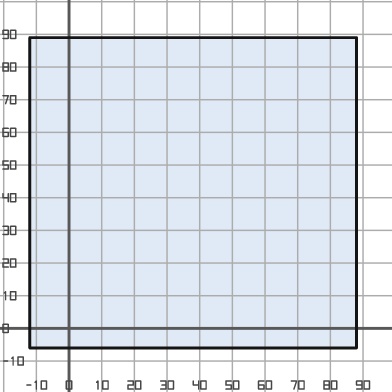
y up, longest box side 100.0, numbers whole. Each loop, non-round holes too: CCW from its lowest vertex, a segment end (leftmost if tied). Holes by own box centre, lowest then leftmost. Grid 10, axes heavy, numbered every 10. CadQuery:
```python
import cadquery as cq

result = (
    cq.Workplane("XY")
    .moveTo(-12.0, -6.0)
    .lineTo(88.0, -6.0)
    .lineTo(88.0, 89.0)
    .lineTo(-12.0, 89.0)
    .close()
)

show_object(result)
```